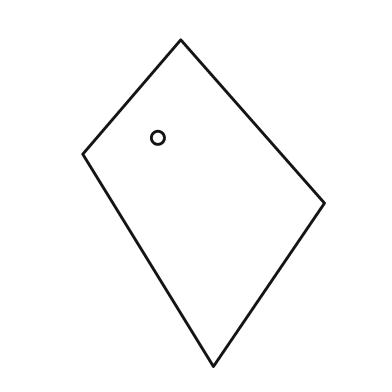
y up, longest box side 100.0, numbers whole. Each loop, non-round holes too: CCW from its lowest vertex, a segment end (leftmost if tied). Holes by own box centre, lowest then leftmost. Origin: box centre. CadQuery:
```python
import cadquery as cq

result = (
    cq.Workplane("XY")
    .moveTo(3.0, -50.0)
    .lineTo(37.0, 0.0)
    .lineTo(-7.0, 50.0)
    .lineTo(-37.0, 15.0)
    .close()
    .moveTo(-14.0, 20.0)
    .circle(2.0)
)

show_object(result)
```